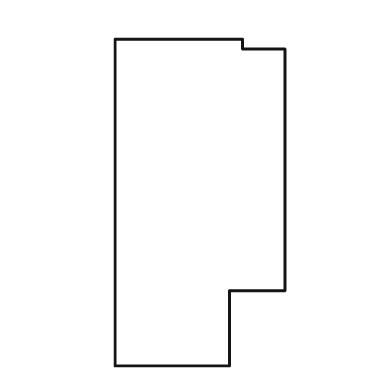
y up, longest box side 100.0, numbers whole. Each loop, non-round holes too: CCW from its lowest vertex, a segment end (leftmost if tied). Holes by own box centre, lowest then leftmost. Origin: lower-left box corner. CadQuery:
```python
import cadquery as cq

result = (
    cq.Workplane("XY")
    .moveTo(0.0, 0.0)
    .lineTo(35.0, 0.0)
    .lineTo(35.0, 23.0)
    .lineTo(52.0, 23.0)
    .lineTo(52.0, 97.0)
    .lineTo(39.0, 97.0)
    .lineTo(39.0, 100.0)
    .lineTo(0.0, 100.0)
    .close()
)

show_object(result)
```